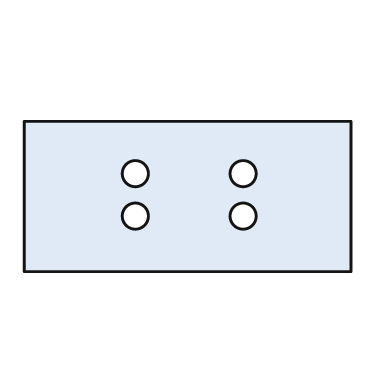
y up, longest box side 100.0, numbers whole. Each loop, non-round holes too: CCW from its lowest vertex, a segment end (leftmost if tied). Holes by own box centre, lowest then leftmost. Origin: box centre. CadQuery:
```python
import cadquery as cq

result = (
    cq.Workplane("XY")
    .moveTo(-50.0, -23.0)
    .lineTo(50.0, -23.0)
    .lineTo(50.0, 23.0)
    .lineTo(-50.0, 23.0)
    .close()
    .moveTo(-16.0, -6.0)
    .circle(4.0)
    .moveTo(17.0, -6.0)
    .circle(4.0)
    .moveTo(-16.0, 7.0)
    .circle(4.0)
    .moveTo(17.0, 7.0)
    .circle(4.0)
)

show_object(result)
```